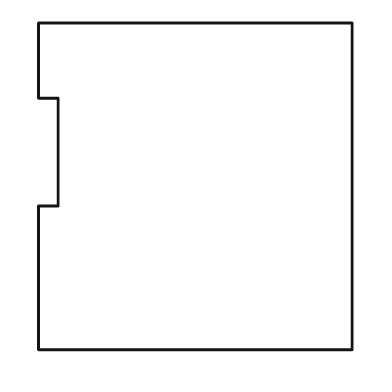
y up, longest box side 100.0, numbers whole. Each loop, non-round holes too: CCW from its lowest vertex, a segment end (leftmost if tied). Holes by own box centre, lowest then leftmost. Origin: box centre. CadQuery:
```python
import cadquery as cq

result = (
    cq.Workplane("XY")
    .moveTo(-48.0, -50.0)
    .lineTo(48.0, -50.0)
    .lineTo(48.0, 50.0)
    .lineTo(-48.0, 50.0)
    .lineTo(-48.0, 27.0)
    .lineTo(-42.0, 27.0)
    .lineTo(-42.0, -6.0)
    .lineTo(-48.0, -6.0)
    .close()
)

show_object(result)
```